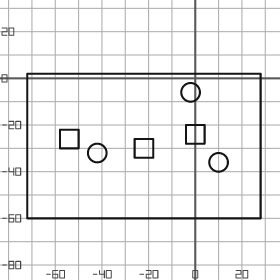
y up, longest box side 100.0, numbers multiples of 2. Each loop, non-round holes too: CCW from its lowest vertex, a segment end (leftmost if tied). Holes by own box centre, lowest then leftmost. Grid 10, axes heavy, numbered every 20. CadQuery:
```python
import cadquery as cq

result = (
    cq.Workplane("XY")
    .moveTo(-72.0, -60.0)
    .lineTo(28.0, -60.0)
    .lineTo(28.0, 2.0)
    .lineTo(-72.0, 2.0)
    .close()
    .moveTo(10.0, -36.0)
    .circle(4.0)
    .moveTo(-42.0, -32.0)
    .circle(4.0)
    .moveTo(-26.0, -34.0)
    .lineTo(-18.0, -34.0)
    .lineTo(-18.0, -26.0)
    .lineTo(-26.0, -26.0)
    .close()
    .moveTo(-58.0, -30.0)
    .lineTo(-50.0, -30.0)
    .lineTo(-50.0, -22.0)
    .lineTo(-58.0, -22.0)
    .close()
    .moveTo(-4.0, -28.0)
    .lineTo(4.0, -28.0)
    .lineTo(4.0, -20.0)
    .lineTo(-4.0, -20.0)
    .close()
    .moveTo(-2.0, -6.0)
    .circle(4.0)
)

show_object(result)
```